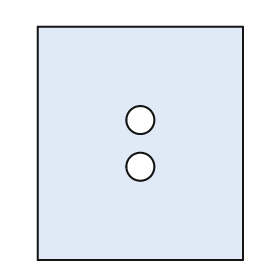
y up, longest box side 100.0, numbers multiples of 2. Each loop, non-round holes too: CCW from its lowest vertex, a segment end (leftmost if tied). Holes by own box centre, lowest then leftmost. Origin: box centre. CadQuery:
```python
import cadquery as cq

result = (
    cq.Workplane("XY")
    .moveTo(-44.0, -50.0)
    .lineTo(44.0, -50.0)
    .lineTo(44.0, 50.0)
    .lineTo(-44.0, 50.0)
    .close()
    .moveTo(0.0, -10.0)
    .circle(6.0)
    .moveTo(0.0, 10.0)
    .circle(6.0)
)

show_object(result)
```